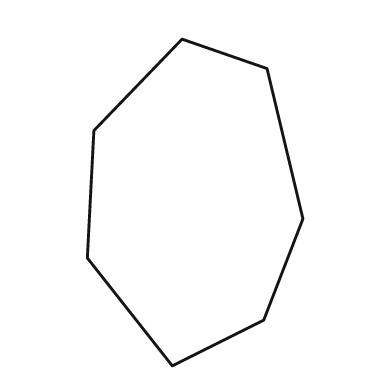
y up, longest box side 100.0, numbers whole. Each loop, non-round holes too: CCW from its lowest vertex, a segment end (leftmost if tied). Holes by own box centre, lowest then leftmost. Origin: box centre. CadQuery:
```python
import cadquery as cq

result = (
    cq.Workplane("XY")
    .moveTo(-7.0, -50.0)
    .lineTo(21.0, -36.0)
    .lineTo(33.0, -5.0)
    .lineTo(22.0, 41.0)
    .lineTo(-4.0, 50.0)
    .lineTo(-31.0, 22.0)
    .lineTo(-33.0, -17.0)
    .close()
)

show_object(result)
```